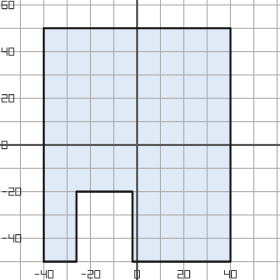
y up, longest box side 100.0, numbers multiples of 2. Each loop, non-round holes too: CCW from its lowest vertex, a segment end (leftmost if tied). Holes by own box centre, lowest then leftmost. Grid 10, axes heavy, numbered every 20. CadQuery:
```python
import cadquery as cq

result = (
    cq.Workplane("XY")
    .moveTo(-40.0, -50.0)
    .lineTo(-26.0, -50.0)
    .lineTo(-26.0, -20.0)
    .lineTo(-2.0, -20.0)
    .lineTo(-2.0, -50.0)
    .lineTo(40.0, -50.0)
    .lineTo(40.0, 50.0)
    .lineTo(-40.0, 50.0)
    .close()
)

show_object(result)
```